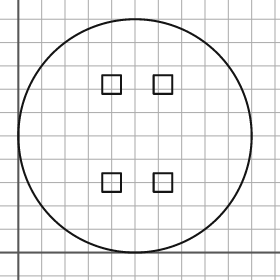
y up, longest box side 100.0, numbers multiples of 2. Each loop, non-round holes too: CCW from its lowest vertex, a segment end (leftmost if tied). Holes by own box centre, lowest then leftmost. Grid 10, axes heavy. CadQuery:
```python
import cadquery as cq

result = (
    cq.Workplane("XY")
    .moveTo(50.0, 50.0)
    .circle(50.0)
    .moveTo(36.0, 26.0)
    .lineTo(44.0, 26.0)
    .lineTo(44.0, 34.0)
    .lineTo(36.0, 34.0)
    .close()
    .moveTo(58.0, 26.0)
    .lineTo(66.0, 26.0)
    .lineTo(66.0, 34.0)
    .lineTo(58.0, 34.0)
    .close()
    .moveTo(36.0, 68.0)
    .lineTo(44.0, 68.0)
    .lineTo(44.0, 76.0)
    .lineTo(36.0, 76.0)
    .close()
    .moveTo(58.0, 68.0)
    .lineTo(66.0, 68.0)
    .lineTo(66.0, 76.0)
    .lineTo(58.0, 76.0)
    .close()
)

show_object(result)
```